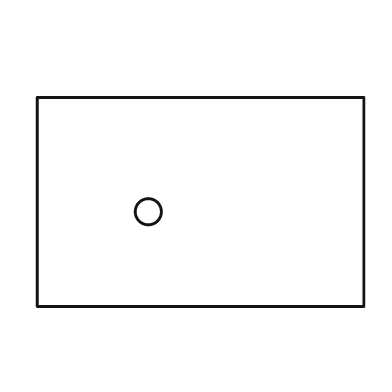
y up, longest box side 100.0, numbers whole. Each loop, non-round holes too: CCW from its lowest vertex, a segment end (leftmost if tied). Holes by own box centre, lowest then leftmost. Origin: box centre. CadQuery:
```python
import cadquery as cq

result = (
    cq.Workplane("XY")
    .moveTo(-50.0, -32.0)
    .lineTo(50.0, -32.0)
    .lineTo(50.0, 32.0)
    .lineTo(-50.0, 32.0)
    .close()
    .moveTo(-16.0, -3.0)
    .circle(4.0)
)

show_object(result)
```